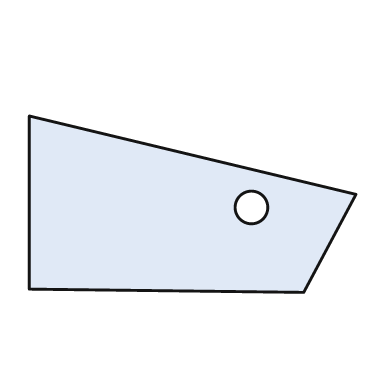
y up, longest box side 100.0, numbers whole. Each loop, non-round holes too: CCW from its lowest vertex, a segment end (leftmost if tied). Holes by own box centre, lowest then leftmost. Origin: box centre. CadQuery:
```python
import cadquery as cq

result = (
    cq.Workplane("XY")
    .moveTo(34.0, -27.0)
    .lineTo(50.0, 3.0)
    .lineTo(-50.0, 27.0)
    .lineTo(-50.0, -26.0)
    .close()
    .moveTo(18.0, -1.0)
    .circle(5.0)
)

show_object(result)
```